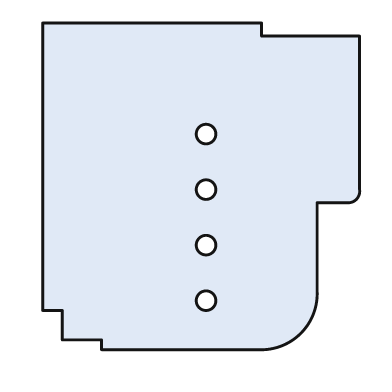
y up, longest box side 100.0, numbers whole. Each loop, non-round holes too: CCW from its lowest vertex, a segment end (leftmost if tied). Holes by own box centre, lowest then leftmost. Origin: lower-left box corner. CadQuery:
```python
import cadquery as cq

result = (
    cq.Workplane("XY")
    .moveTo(18.0, 0.0)
    .lineTo(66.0, 0.0)
    .threePointArc((79.0, 5.0), (84.0, 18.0))
    .lineTo(84.0, 45.0)
    .lineTo(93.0, 45.0)
    .threePointArc((96.0, 46.0), (97.0, 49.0))
    .lineTo(97.0, 96.0)
    .lineTo(67.0, 96.0)
    .lineTo(67.0, 100.0)
    .lineTo(0.0, 100.0)
    .lineTo(0.0, 12.0)
    .lineTo(6.0, 12.0)
    .lineTo(6.0, 3.0)
    .lineTo(18.0, 3.0)
    .close()
    .moveTo(50.0, 15.0)
    .circle(3.0)
    .moveTo(50.0, 32.0)
    .circle(3.0)
    .moveTo(50.0, 49.0)
    .circle(3.0)
    .moveTo(50.0, 66.0)
    .circle(3.0)
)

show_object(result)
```